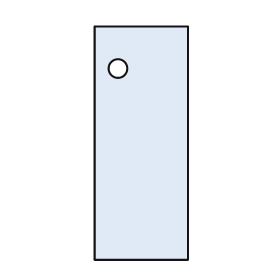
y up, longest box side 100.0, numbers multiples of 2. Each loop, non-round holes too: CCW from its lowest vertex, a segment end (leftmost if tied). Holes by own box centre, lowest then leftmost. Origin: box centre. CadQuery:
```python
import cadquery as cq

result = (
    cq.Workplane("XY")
    .moveTo(-20.0, -50.0)
    .lineTo(20.0, -50.0)
    .lineTo(20.0, 50.0)
    .lineTo(-20.0, 50.0)
    .close()
    .moveTo(-10.0, 32.0)
    .circle(4.0)
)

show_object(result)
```